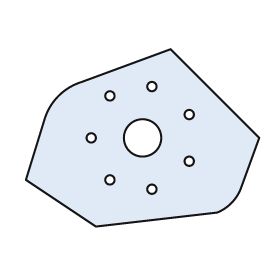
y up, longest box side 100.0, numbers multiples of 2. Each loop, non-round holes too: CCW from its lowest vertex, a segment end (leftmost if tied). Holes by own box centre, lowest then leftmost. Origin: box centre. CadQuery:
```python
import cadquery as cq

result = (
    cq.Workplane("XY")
    .moveTo(-20.0, -38.0)
    .lineTo(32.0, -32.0)
    .threePointArc((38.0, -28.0), (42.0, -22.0))
    .lineTo(50.0, 0.0)
    .lineTo(12.0, 38.0)
    .lineTo(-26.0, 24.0)
    .threePointArc((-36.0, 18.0), (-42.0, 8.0))
    .lineTo(-50.0, -18.0)
    .close()
    .moveTo(4.0, -22.0)
    .circle(2.0)
    .moveTo(-14.0, -18.0)
    .circle(2.0)
    .moveTo(20.0, -10.0)
    .circle(2.0)
    .moveTo(-22.0, 0.0)
    .circle(2.0)
    .moveTo(0.0, 0.0)
    .circle(8.0)
    .moveTo(20.0, 10.0)
    .circle(2.0)
    .moveTo(-14.0, 18.0)
    .circle(2.0)
    .moveTo(4.0, 22.0)
    .circle(2.0)
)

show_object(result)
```